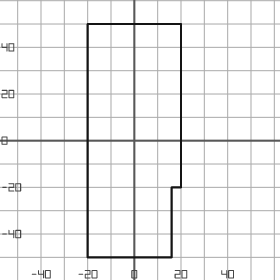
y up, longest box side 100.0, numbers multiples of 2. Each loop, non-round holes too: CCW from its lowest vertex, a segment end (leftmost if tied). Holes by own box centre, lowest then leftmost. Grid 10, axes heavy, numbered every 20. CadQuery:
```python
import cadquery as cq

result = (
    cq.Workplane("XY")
    .moveTo(-20.0, -50.0)
    .lineTo(16.0, -50.0)
    .lineTo(16.0, -20.0)
    .lineTo(20.0, -20.0)
    .lineTo(20.0, 50.0)
    .lineTo(-20.0, 50.0)
    .close()
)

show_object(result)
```